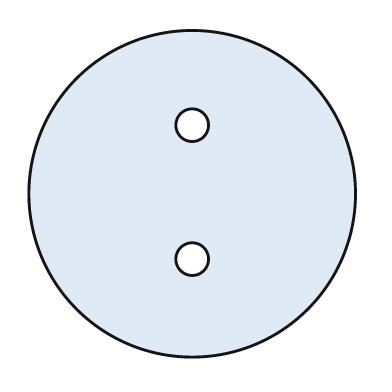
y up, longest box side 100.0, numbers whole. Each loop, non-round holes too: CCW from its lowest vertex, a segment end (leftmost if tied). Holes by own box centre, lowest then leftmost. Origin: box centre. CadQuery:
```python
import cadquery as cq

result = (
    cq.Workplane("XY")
    .moveTo(0.0, 0.0)
    .circle(50.0)
    .moveTo(0.0, -20.0)
    .circle(5.0)
    .moveTo(0.0, 21.0)
    .circle(5.0)
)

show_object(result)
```